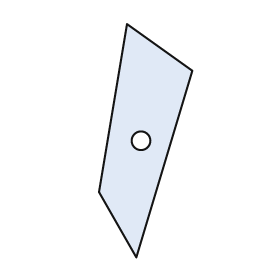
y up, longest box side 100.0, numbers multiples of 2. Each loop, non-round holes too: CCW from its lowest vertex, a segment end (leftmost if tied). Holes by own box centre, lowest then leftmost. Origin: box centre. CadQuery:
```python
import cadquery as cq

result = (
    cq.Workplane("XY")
    .moveTo(-4.0, -50.0)
    .lineTo(20.0, 30.0)
    .lineTo(-8.0, 50.0)
    .lineTo(-20.0, -22.0)
    .close()
    .moveTo(-2.0, 0.0)
    .circle(4.0)
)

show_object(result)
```